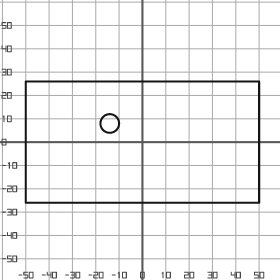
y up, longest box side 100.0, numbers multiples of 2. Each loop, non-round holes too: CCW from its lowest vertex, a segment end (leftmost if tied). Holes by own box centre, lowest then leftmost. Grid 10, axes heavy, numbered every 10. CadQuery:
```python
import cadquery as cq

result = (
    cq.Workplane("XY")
    .moveTo(-50.0, -26.0)
    .lineTo(50.0, -26.0)
    .lineTo(50.0, 26.0)
    .lineTo(-50.0, 26.0)
    .close()
    .moveTo(-14.0, 8.0)
    .circle(4.0)
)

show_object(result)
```